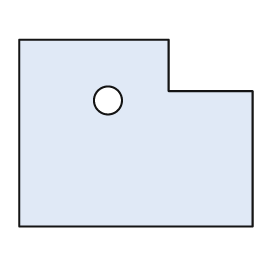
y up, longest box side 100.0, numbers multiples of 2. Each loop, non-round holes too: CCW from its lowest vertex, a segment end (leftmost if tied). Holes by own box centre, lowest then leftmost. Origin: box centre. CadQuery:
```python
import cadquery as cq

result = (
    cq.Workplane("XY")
    .moveTo(-50.0, -40.0)
    .lineTo(50.0, -40.0)
    .lineTo(50.0, 18.0)
    .lineTo(14.0, 18.0)
    .lineTo(14.0, 40.0)
    .lineTo(-50.0, 40.0)
    .close()
    .moveTo(-12.0, 14.0)
    .circle(6.0)
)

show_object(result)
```